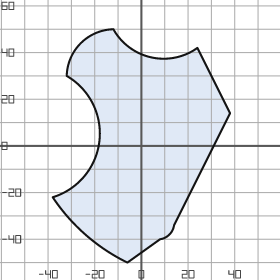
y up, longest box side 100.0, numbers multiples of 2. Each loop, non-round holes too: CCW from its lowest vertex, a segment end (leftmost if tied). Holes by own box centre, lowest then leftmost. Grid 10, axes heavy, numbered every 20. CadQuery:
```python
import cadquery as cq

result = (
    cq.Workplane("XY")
    .moveTo(-6.0, -50.0)
    .lineTo(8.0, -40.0)
    .threePointArc((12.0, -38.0), (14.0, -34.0))
    .lineTo(38.0, 14.0)
    .lineTo(24.0, 42.0)
    .threePointArc((4.0, 38.0), (-12.0, 50.0))
    .threePointArc((-26.0, 44.0), (-32.0, 30.0))
    .threePointArc((-18.0, 2.0), (-38.0, -22.0))
    .threePointArc((-24.0, -38.0), (-6.0, -50.0))
    .close()
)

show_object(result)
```